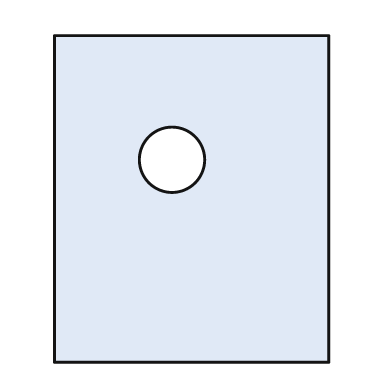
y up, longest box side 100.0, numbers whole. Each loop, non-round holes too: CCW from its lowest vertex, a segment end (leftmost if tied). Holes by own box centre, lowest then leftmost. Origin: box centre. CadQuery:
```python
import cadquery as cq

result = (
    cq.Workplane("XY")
    .moveTo(-42.0, -50.0)
    .lineTo(42.0, -50.0)
    .lineTo(42.0, 50.0)
    .lineTo(-42.0, 50.0)
    .close()
    .moveTo(-6.0, 12.0)
    .circle(10.0)
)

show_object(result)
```